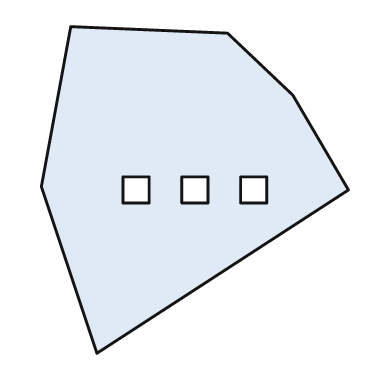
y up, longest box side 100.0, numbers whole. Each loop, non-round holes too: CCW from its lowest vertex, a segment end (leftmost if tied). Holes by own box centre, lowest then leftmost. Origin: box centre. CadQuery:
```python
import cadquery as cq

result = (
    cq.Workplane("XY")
    .moveTo(-30.0, -50.0)
    .lineTo(47.0, 0.0)
    .lineTo(30.0, 29.0)
    .lineTo(10.0, 48.0)
    .lineTo(-38.0, 50.0)
    .lineTo(-47.0, 1.0)
    .close()
    .moveTo(-22.0, -4.0)
    .lineTo(-14.0, -4.0)
    .lineTo(-14.0, 4.0)
    .lineTo(-22.0, 4.0)
    .close()
    .moveTo(-4.0, -4.0)
    .lineTo(4.0, -4.0)
    .lineTo(4.0, 4.0)
    .lineTo(-4.0, 4.0)
    .close()
    .moveTo(14.0, -4.0)
    .lineTo(22.0, -4.0)
    .lineTo(22.0, 4.0)
    .lineTo(14.0, 4.0)
    .close()
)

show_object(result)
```